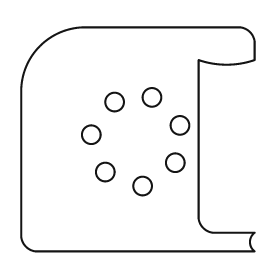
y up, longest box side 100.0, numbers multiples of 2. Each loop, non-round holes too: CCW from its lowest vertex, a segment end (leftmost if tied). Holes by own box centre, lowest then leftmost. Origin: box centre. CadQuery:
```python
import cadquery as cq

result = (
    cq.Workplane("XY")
    .moveTo(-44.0, -48.0)
    .lineTo(50.0, -48.0)
    .threePointArc((48.0, -44.0), (50.0, -40.0))
    .lineTo(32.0, -40.0)
    .threePointArc((28.0, -38.0), (26.0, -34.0))
    .lineTo(26.0, 34.0)
    .threePointArc((38.0, 32.0), (50.0, 34.0))
    .lineTo(50.0, 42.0)
    .threePointArc((48.0, 46.0), (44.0, 48.0))
    .lineTo(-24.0, 48.0)
    .threePointArc((-42.0, 40.0), (-50.0, 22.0))
    .lineTo(-50.0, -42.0)
    .threePointArc((-48.0, -46.0), (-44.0, -48.0))
    .close()
    .moveTo(2.0, -20.0)
    .circle(4.0)
    .moveTo(-14.0, -14.0)
    .circle(4.0)
    .moveTo(16.0, -10.0)
    .circle(4.0)
    .moveTo(-20.0, 2.0)
    .circle(4.0)
    .moveTo(18.0, 6.0)
    .circle(4.0)
    .moveTo(-10.0, 16.0)
    .circle(4.0)
    .moveTo(6.0, 18.0)
    .circle(4.0)
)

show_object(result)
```